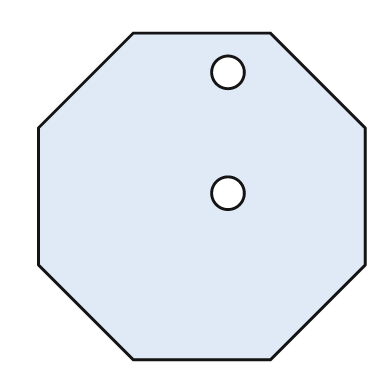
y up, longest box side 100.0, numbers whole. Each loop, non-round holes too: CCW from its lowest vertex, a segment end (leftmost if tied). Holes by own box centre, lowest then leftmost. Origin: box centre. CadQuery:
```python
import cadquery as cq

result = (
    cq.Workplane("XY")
    .moveTo(-21.0, -50.0)
    .lineTo(21.0, -50.0)
    .lineTo(50.0, -21.0)
    .lineTo(50.0, 21.0)
    .lineTo(21.0, 50.0)
    .lineTo(-21.0, 50.0)
    .lineTo(-50.0, 21.0)
    .lineTo(-50.0, -21.0)
    .close()
    .moveTo(8.0, 1.0)
    .circle(5.0)
    .moveTo(8.0, 38.0)
    .circle(5.0)
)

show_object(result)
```